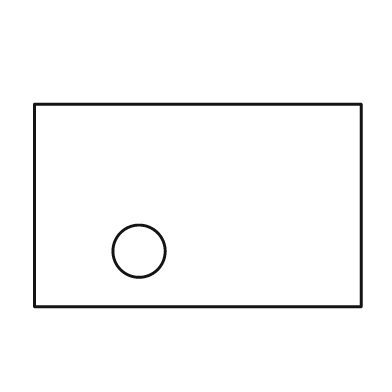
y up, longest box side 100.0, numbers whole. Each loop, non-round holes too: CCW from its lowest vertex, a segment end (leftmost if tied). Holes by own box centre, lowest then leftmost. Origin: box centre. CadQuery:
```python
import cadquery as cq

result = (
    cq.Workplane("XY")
    .moveTo(-50.0, -31.0)
    .lineTo(50.0, -31.0)
    .lineTo(50.0, 31.0)
    .lineTo(-50.0, 31.0)
    .close()
    .moveTo(-18.0, -14.0)
    .circle(8.0)
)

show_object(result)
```